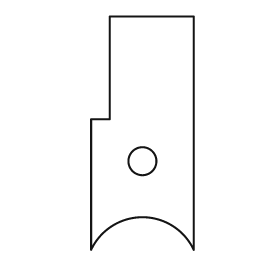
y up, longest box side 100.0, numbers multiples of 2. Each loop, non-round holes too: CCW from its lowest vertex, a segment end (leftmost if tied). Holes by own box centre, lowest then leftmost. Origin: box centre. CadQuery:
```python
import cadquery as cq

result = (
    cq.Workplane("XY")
    .moveTo(-22.0, -50.0)
    .threePointArc((0.0, -36.0), (22.0, -50.0))
    .lineTo(22.0, 50.0)
    .lineTo(-14.0, 50.0)
    .lineTo(-14.0, 6.0)
    .lineTo(-22.0, 6.0)
    .close()
    .moveTo(0.0, -12.0)
    .circle(6.0)
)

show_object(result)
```